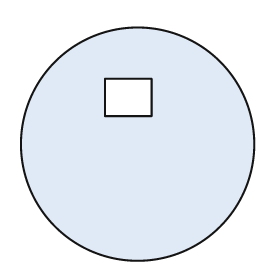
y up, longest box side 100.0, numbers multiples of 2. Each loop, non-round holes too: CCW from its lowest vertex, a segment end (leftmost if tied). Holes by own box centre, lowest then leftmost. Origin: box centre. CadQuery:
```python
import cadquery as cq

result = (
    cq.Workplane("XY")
    .moveTo(0.0, 0.0)
    .circle(50.0)
    .moveTo(-14.0, 12.0)
    .lineTo(6.0, 12.0)
    .lineTo(6.0, 28.0)
    .lineTo(-14.0, 28.0)
    .close()
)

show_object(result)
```